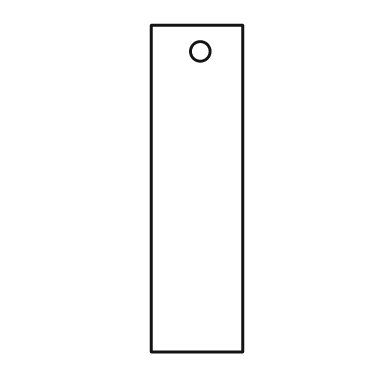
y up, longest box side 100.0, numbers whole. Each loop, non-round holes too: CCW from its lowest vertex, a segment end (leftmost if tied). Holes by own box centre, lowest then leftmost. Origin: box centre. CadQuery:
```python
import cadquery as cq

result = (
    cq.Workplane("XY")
    .moveTo(-14.0, -50.0)
    .lineTo(14.0, -50.0)
    .lineTo(14.0, 50.0)
    .lineTo(-14.0, 50.0)
    .close()
    .moveTo(1.0, 42.0)
    .circle(3.0)
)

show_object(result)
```